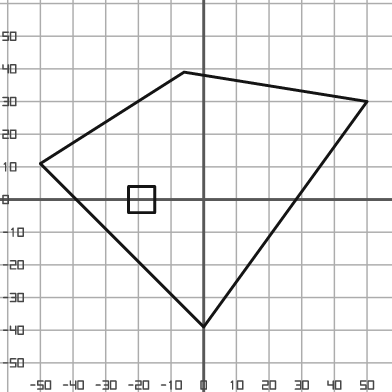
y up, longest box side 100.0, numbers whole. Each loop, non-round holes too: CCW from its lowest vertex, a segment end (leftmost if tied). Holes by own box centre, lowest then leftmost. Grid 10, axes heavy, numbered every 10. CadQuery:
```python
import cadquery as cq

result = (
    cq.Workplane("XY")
    .moveTo(0.0, -39.0)
    .lineTo(50.0, 30.0)
    .lineTo(-6.0, 39.0)
    .lineTo(-50.0, 11.0)
    .close()
    .moveTo(-23.0, -4.0)
    .lineTo(-15.0, -4.0)
    .lineTo(-15.0, 4.0)
    .lineTo(-23.0, 4.0)
    .close()
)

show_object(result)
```